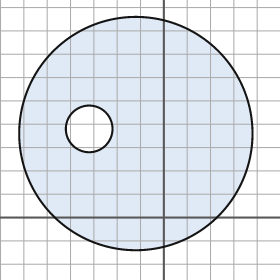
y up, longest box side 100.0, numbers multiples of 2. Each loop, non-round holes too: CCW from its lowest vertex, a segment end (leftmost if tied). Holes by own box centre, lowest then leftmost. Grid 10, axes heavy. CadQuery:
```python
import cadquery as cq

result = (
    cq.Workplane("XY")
    .moveTo(-12.0, 36.0)
    .circle(50.0)
    .moveTo(-32.0, 38.0)
    .circle(10.0)
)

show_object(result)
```